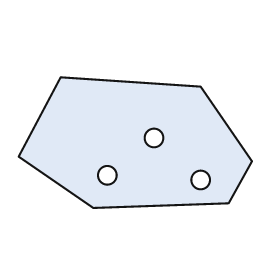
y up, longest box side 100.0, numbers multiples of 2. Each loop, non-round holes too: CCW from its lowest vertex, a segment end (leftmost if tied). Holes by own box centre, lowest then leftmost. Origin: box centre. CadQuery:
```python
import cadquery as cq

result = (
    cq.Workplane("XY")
    .moveTo(-18.0, -28.0)
    .lineTo(40.0, -26.0)
    .lineTo(50.0, -8.0)
    .lineTo(28.0, 24.0)
    .lineTo(-32.0, 28.0)
    .lineTo(-50.0, -6.0)
    .close()
    .moveTo(28.0, -16.0)
    .circle(4.0)
    .moveTo(-12.0, -14.0)
    .circle(4.0)
    .moveTo(8.0, 2.0)
    .circle(4.0)
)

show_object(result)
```